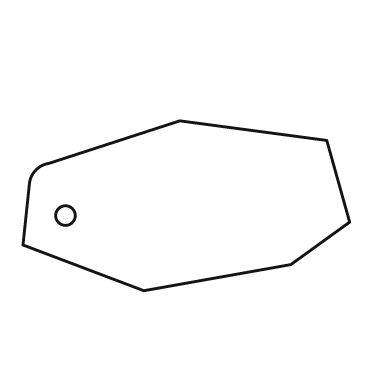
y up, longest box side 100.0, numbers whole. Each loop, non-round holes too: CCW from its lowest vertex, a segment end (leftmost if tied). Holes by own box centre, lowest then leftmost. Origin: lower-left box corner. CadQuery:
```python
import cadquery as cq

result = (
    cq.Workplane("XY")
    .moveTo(37.0, 0.0)
    .lineTo(82.0, 8.0)
    .lineTo(100.0, 21.0)
    .lineTo(93.0, 46.0)
    .lineTo(48.0, 52.0)
    .lineTo(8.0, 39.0)
    .threePointArc((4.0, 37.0), (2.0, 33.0))
    .lineTo(0.0, 14.0)
    .close()
    .moveTo(13.0, 23.0)
    .circle(3.0)
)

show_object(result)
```